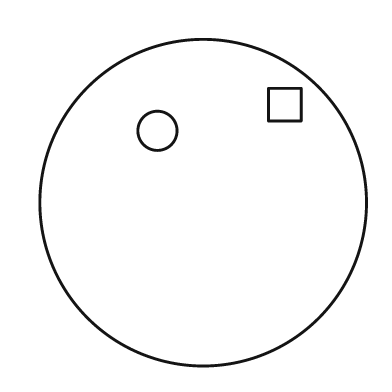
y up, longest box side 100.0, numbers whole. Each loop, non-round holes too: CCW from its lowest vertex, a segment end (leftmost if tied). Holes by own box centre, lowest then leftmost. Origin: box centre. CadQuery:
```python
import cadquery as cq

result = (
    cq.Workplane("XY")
    .moveTo(0.0, 0.0)
    .circle(50.0)
    .moveTo(-14.0, 22.0)
    .circle(6.0)
    .moveTo(20.0, 25.0)
    .lineTo(30.0, 25.0)
    .lineTo(30.0, 35.0)
    .lineTo(20.0, 35.0)
    .close()
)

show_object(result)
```